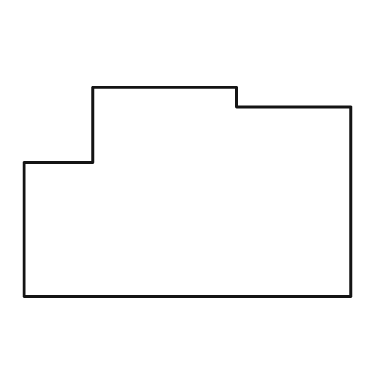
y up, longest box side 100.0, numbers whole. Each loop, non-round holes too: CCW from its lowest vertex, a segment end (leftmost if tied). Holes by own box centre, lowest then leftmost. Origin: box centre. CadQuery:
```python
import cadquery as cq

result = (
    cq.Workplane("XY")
    .moveTo(-50.0, -32.0)
    .lineTo(50.0, -32.0)
    .lineTo(50.0, 26.0)
    .lineTo(15.0, 26.0)
    .lineTo(15.0, 32.0)
    .lineTo(-29.0, 32.0)
    .lineTo(-29.0, 9.0)
    .lineTo(-50.0, 9.0)
    .close()
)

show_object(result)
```